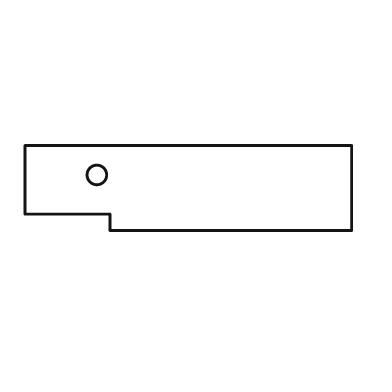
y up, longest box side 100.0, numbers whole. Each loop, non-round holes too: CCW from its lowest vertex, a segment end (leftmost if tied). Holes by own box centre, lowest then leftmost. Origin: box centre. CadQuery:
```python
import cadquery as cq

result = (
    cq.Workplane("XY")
    .moveTo(-24.0, -13.0)
    .lineTo(50.0, -13.0)
    .lineTo(50.0, 13.0)
    .lineTo(-50.0, 13.0)
    .lineTo(-50.0, -8.0)
    .lineTo(-24.0, -8.0)
    .close()
    .moveTo(-28.0, 4.0)
    .circle(3.0)
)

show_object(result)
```